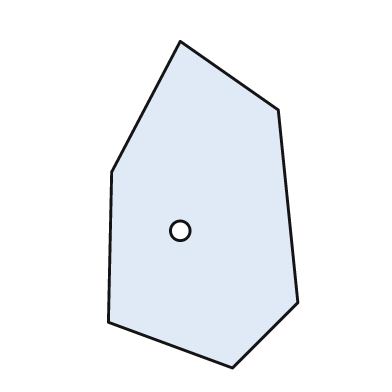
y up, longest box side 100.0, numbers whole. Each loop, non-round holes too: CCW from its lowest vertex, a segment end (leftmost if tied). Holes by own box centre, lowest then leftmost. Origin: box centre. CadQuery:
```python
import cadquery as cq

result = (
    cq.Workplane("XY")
    .moveTo(9.0, -50.0)
    .lineTo(29.0, -30.0)
    .lineTo(23.0, 29.0)
    .lineTo(-7.0, 50.0)
    .lineTo(-28.0, 10.0)
    .lineTo(-29.0, -36.0)
    .close()
    .moveTo(-7.0, -8.0)
    .circle(3.0)
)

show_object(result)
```